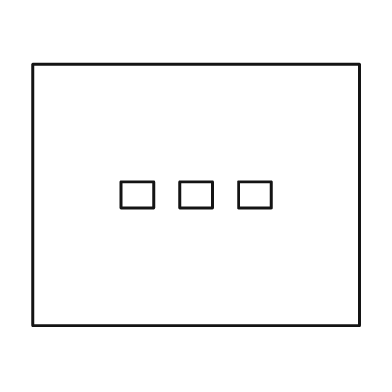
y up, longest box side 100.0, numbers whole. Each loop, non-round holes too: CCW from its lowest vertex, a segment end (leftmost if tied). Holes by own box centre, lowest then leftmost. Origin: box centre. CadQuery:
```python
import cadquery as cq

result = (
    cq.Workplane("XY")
    .moveTo(-50.0, -40.0)
    .lineTo(50.0, -40.0)
    .lineTo(50.0, 40.0)
    .lineTo(-50.0, 40.0)
    .close()
    .moveTo(-23.0, -4.0)
    .lineTo(-13.0, -4.0)
    .lineTo(-13.0, 4.0)
    .lineTo(-23.0, 4.0)
    .close()
    .moveTo(-5.0, -4.0)
    .lineTo(5.0, -4.0)
    .lineTo(5.0, 4.0)
    .lineTo(-5.0, 4.0)
    .close()
    .moveTo(13.0, -4.0)
    .lineTo(23.0, -4.0)
    .lineTo(23.0, 4.0)
    .lineTo(13.0, 4.0)
    .close()
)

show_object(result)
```